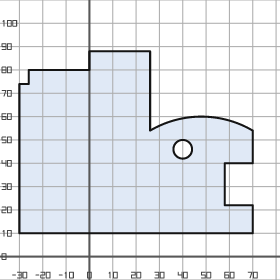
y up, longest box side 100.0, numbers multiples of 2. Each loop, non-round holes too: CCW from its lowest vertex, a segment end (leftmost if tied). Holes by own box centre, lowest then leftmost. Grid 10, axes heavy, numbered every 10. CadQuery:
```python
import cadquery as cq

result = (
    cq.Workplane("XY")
    .moveTo(-30.0, 10.0)
    .lineTo(70.0, 10.0)
    .lineTo(70.0, 22.0)
    .lineTo(58.0, 22.0)
    .lineTo(58.0, 40.0)
    .lineTo(70.0, 40.0)
    .lineTo(70.0, 54.0)
    .threePointArc((48.0, 60.0), (26.0, 54.0))
    .lineTo(26.0, 88.0)
    .lineTo(0.0, 88.0)
    .lineTo(0.0, 80.0)
    .lineTo(-26.0, 80.0)
    .lineTo(-26.0, 74.0)
    .lineTo(-30.0, 74.0)
    .close()
    .moveTo(40.0, 46.0)
    .circle(4.0)
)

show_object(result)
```